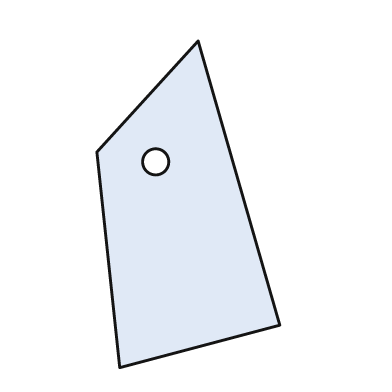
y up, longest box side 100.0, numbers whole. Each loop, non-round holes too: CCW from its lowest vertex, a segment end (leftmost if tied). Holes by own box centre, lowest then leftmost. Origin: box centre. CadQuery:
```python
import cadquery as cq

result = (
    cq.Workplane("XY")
    .moveTo(-21.0, -50.0)
    .lineTo(28.0, -37.0)
    .lineTo(3.0, 50.0)
    .lineTo(-28.0, 16.0)
    .close()
    .moveTo(-10.0, 13.0)
    .circle(4.0)
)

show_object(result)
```